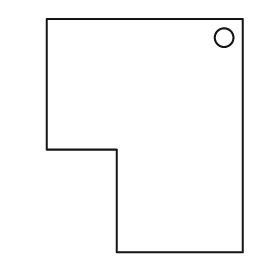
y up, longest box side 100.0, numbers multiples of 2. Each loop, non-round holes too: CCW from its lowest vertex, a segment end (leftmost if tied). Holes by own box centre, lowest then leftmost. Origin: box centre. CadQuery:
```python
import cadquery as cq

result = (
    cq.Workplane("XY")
    .moveTo(-12.0, -50.0)
    .lineTo(42.0, -50.0)
    .lineTo(42.0, 50.0)
    .lineTo(-42.0, 50.0)
    .lineTo(-42.0, -6.0)
    .lineTo(-12.0, -6.0)
    .close()
    .moveTo(34.0, 42.0)
    .circle(4.0)
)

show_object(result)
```